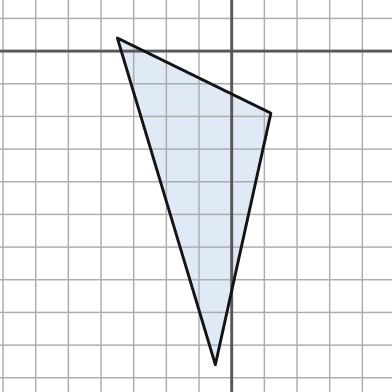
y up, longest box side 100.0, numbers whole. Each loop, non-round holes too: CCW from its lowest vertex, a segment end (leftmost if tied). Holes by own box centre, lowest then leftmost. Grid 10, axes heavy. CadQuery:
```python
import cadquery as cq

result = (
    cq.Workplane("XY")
    .moveTo(-5.0, -96.0)
    .lineTo(12.0, -19.0)
    .lineTo(-35.0, 4.0)
    .close()
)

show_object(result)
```